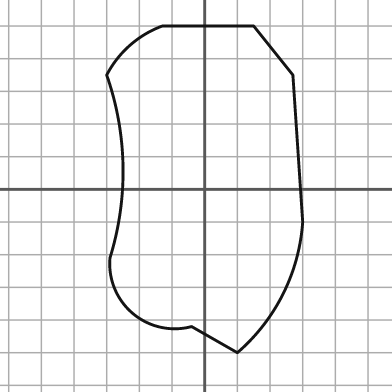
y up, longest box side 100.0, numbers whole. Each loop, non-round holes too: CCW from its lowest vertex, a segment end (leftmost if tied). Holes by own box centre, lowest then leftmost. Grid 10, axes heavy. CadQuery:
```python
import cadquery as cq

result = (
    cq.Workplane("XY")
    .moveTo(10.0, -50.0)
    .threePointArc((24.0, -32.0), (30.0, -10.0))
    .lineTo(27.0, 35.0)
    .lineTo(15.0, 50.0)
    .lineTo(-13.0, 50.0)
    .threePointArc((-23.0, 44.0), (-30.0, 35.0))
    .threePointArc((-25.0, 7.0), (-29.0, -21.0))
    .threePointArc((-22.0, -38.0), (-4.0, -42.0))
    .close()
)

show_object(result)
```